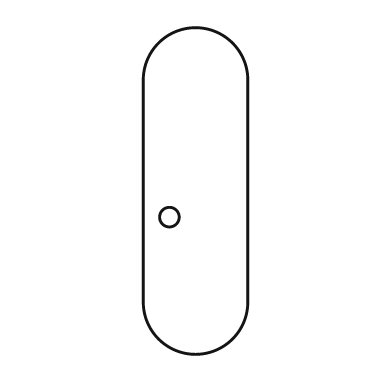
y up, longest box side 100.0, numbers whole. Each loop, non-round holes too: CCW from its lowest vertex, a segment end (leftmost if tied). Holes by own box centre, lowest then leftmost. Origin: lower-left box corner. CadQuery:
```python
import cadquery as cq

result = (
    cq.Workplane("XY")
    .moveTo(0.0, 16.0)
    .threePointArc((16.0, 0.0), (32.0, 16.0))
    .lineTo(32.0, 84.0)
    .threePointArc((16.0, 100.0), (0.0, 84.0))
    .close()
    .moveTo(8.0, 42.0)
    .circle(3.0)
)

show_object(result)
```